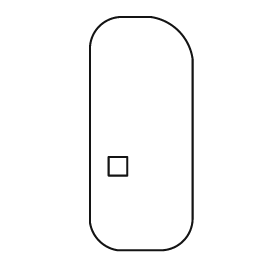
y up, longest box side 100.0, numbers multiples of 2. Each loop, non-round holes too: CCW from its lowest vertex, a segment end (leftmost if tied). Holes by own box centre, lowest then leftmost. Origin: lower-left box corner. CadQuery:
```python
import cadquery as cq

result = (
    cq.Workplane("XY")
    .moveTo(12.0, 0.0)
    .lineTo(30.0, 0.0)
    .threePointArc((40.0, 4.0), (44.0, 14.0))
    .lineTo(44.0, 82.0)
    .threePointArc((38.0, 94.0), (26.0, 100.0))
    .lineTo(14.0, 100.0)
    .threePointArc((4.0, 96.0), (0.0, 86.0))
    .lineTo(0.0, 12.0)
    .threePointArc((4.0, 4.0), (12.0, 0.0))
    .close()
    .moveTo(8.0, 32.0)
    .lineTo(16.0, 32.0)
    .lineTo(16.0, 40.0)
    .lineTo(8.0, 40.0)
    .close()
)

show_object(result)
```